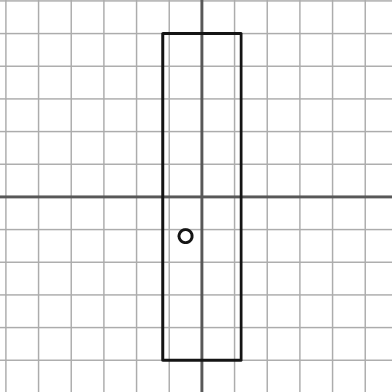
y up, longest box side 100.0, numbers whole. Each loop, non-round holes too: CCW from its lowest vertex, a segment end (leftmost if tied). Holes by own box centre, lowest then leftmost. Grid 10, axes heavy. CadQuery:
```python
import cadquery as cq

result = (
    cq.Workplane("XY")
    .moveTo(-12.0, -50.0)
    .lineTo(12.0, -50.0)
    .lineTo(12.0, 50.0)
    .lineTo(-12.0, 50.0)
    .close()
    .moveTo(-5.0, -12.0)
    .circle(2.0)
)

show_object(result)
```